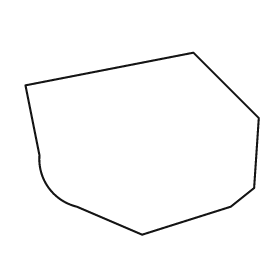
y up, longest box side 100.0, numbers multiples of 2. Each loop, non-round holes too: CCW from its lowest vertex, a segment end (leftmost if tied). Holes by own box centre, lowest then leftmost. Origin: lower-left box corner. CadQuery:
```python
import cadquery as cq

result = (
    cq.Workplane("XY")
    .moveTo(50.0, 0.0)
    .lineTo(88.0, 12.0)
    .lineTo(98.0, 20.0)
    .lineTo(100.0, 50.0)
    .lineTo(72.0, 78.0)
    .lineTo(0.0, 64.0)
    .lineTo(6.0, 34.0)
    .threePointArc((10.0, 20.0), (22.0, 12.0))
    .close()
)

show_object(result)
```